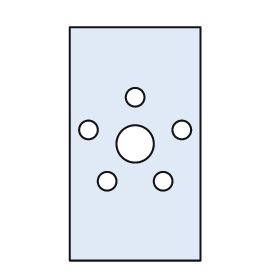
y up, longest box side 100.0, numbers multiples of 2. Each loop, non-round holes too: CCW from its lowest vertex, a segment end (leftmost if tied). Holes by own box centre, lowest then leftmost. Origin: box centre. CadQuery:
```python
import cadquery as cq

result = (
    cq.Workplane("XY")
    .moveTo(-28.0, -50.0)
    .lineTo(28.0, -50.0)
    .lineTo(28.0, 50.0)
    .lineTo(-28.0, 50.0)
    .close()
    .moveTo(-12.0, -16.0)
    .circle(4.0)
    .moveTo(12.0, -16.0)
    .circle(4.0)
    .moveTo(0.0, 0.0)
    .circle(8.0)
    .moveTo(-20.0, 6.0)
    .circle(4.0)
    .moveTo(20.0, 6.0)
    .circle(4.0)
    .moveTo(0.0, 20.0)
    .circle(4.0)
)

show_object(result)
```